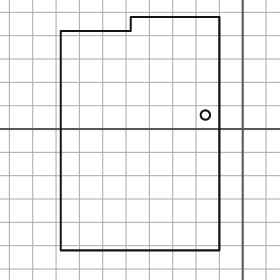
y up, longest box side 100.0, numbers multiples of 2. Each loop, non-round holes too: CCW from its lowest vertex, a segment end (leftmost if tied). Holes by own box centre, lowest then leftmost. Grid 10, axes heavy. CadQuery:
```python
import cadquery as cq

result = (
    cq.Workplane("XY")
    .moveTo(-78.0, -52.0)
    .lineTo(-10.0, -52.0)
    .lineTo(-10.0, 48.0)
    .lineTo(-48.0, 48.0)
    .lineTo(-48.0, 42.0)
    .lineTo(-78.0, 42.0)
    .close()
    .moveTo(-16.0, 6.0)
    .circle(2.0)
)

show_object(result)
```